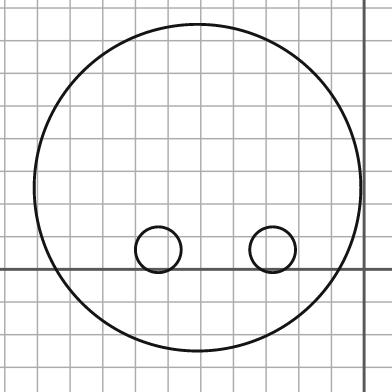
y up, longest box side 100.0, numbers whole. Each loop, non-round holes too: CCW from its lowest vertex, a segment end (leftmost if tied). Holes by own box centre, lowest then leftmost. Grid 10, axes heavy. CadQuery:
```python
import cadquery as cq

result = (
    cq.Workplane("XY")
    .moveTo(-51.0, 25.0)
    .circle(50.0)
    .moveTo(-63.0, 6.0)
    .circle(7.0)
    .moveTo(-28.0, 6.0)
    .circle(7.0)
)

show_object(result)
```